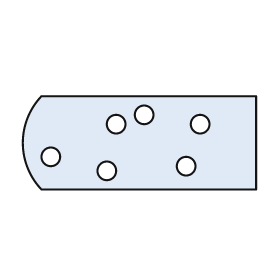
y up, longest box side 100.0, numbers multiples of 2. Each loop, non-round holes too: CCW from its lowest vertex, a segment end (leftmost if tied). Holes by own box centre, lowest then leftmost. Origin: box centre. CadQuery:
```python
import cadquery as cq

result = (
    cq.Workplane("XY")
    .moveTo(-42.0, -20.0)
    .lineTo(50.0, -20.0)
    .lineTo(50.0, 20.0)
    .lineTo(-42.0, 20.0)
    .threePointArc((-50.0, 0.0), (-42.0, -20.0))
    .close()
    .moveTo(-14.0, -12.0)
    .circle(4.0)
    .moveTo(20.0, -10.0)
    .circle(4.0)
    .moveTo(-38.0, -6.0)
    .circle(4.0)
    .moveTo(-10.0, 8.0)
    .circle(4.0)
    .moveTo(26.0, 8.0)
    .circle(4.0)
    .moveTo(2.0, 12.0)
    .circle(4.0)
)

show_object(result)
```